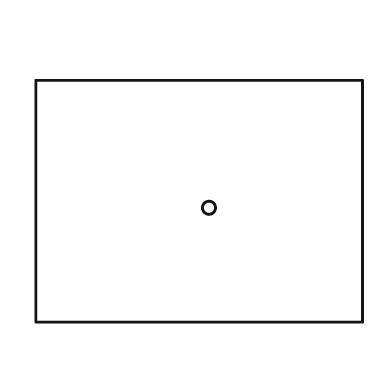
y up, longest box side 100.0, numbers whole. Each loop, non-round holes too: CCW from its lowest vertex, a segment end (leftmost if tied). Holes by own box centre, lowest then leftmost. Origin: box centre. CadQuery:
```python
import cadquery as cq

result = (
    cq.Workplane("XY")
    .moveTo(-50.0, -37.0)
    .lineTo(50.0, -37.0)
    .lineTo(50.0, 37.0)
    .lineTo(-50.0, 37.0)
    .close()
    .moveTo(3.0, -2.0)
    .circle(2.0)
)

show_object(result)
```